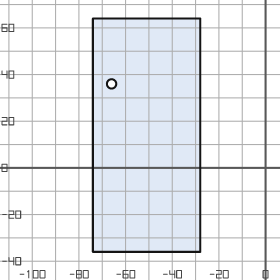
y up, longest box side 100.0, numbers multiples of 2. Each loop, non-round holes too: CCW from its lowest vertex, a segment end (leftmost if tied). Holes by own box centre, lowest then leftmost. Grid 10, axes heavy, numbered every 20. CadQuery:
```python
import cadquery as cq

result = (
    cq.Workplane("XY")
    .moveTo(-74.0, -36.0)
    .lineTo(-28.0, -36.0)
    .lineTo(-28.0, 64.0)
    .lineTo(-74.0, 64.0)
    .close()
    .moveTo(-66.0, 36.0)
    .circle(2.0)
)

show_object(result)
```